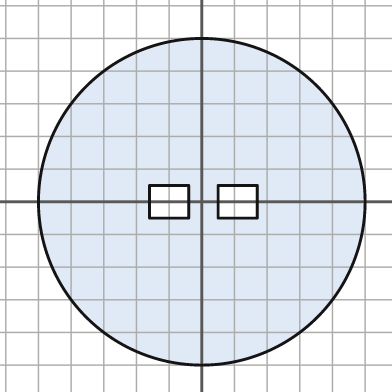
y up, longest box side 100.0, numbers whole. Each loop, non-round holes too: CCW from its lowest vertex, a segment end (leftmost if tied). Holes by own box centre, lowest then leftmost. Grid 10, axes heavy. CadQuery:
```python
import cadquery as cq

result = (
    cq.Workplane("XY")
    .moveTo(0.0, 0.0)
    .circle(50.0)
    .moveTo(-16.0, -5.0)
    .lineTo(-4.0, -5.0)
    .lineTo(-4.0, 5.0)
    .lineTo(-16.0, 5.0)
    .close()
    .moveTo(5.0, -5.0)
    .lineTo(17.0, -5.0)
    .lineTo(17.0, 5.0)
    .lineTo(5.0, 5.0)
    .close()
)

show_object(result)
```